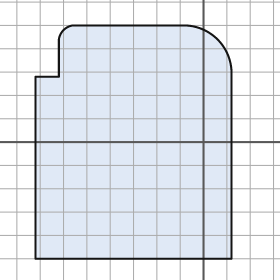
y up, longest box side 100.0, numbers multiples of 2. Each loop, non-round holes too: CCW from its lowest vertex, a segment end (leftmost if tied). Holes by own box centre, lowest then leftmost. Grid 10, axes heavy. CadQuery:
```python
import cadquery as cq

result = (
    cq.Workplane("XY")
    .moveTo(-72.0, -50.0)
    .lineTo(12.0, -50.0)
    .lineTo(12.0, 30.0)
    .threePointArc((6.0, 44.0), (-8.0, 50.0))
    .lineTo(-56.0, 50.0)
    .threePointArc((-60.0, 48.0), (-62.0, 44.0))
    .lineTo(-62.0, 28.0)
    .lineTo(-72.0, 28.0)
    .close()
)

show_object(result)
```